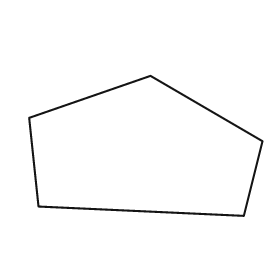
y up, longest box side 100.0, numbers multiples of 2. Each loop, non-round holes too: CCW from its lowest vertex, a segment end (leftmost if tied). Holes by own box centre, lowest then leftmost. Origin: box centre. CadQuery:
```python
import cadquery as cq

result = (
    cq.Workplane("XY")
    .moveTo(42.0, -30.0)
    .lineTo(50.0, 2.0)
    .lineTo(2.0, 30.0)
    .lineTo(-50.0, 12.0)
    .lineTo(-46.0, -26.0)
    .close()
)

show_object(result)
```